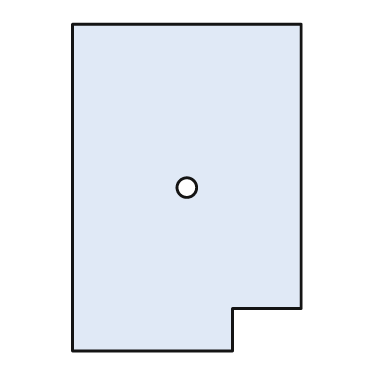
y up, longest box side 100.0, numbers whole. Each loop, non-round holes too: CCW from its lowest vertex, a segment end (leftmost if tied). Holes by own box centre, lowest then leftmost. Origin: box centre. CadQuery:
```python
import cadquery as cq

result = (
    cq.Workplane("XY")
    .moveTo(-35.0, -50.0)
    .lineTo(14.0, -50.0)
    .lineTo(14.0, -37.0)
    .lineTo(35.0, -37.0)
    .lineTo(35.0, 50.0)
    .lineTo(-35.0, 50.0)
    .close()
    .moveTo(0.0, 0.0)
    .circle(3.0)
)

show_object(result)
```